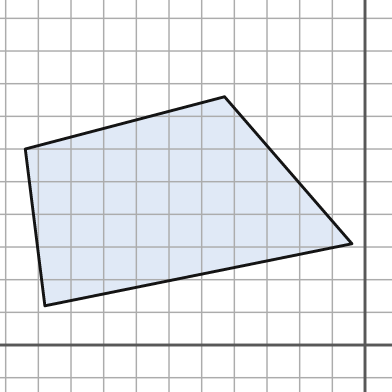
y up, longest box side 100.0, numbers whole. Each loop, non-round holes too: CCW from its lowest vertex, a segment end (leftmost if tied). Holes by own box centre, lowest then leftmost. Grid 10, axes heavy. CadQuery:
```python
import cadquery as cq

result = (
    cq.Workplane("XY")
    .moveTo(-98.0, 12.0)
    .lineTo(-4.0, 31.0)
    .lineTo(-43.0, 76.0)
    .lineTo(-104.0, 60.0)
    .close()
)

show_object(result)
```